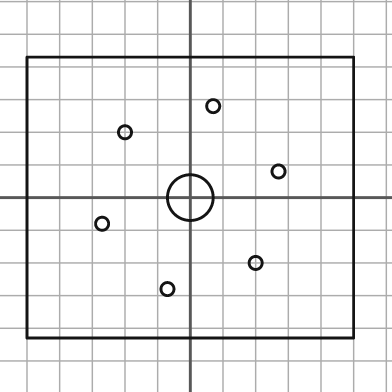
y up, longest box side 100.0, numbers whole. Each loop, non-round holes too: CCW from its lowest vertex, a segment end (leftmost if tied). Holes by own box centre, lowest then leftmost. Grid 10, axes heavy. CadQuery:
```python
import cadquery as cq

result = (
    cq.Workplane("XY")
    .moveTo(-50.0, -43.0)
    .lineTo(50.0, -43.0)
    .lineTo(50.0, 43.0)
    .lineTo(-50.0, 43.0)
    .close()
    .moveTo(-7.0, -28.0)
    .circle(2.0)
    .moveTo(20.0, -20.0)
    .circle(2.0)
    .moveTo(-27.0, -8.0)
    .circle(2.0)
    .moveTo(0.0, 0.0)
    .circle(7.0)
    .moveTo(27.0, 8.0)
    .circle(2.0)
    .moveTo(-20.0, 20.0)
    .circle(2.0)
    .moveTo(7.0, 28.0)
    .circle(2.0)
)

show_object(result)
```